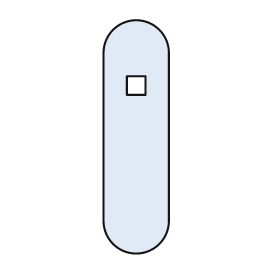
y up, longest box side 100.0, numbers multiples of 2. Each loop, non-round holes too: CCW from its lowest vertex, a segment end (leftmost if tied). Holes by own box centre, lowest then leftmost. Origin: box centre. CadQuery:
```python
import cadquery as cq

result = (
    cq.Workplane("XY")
    .moveTo(-14.0, -36.0)
    .threePointArc((0.0, -50.0), (14.0, -36.0))
    .lineTo(14.0, 36.0)
    .threePointArc((0.0, 50.0), (-14.0, 36.0))
    .close()
    .moveTo(-4.0, 18.0)
    .lineTo(4.0, 18.0)
    .lineTo(4.0, 26.0)
    .lineTo(-4.0, 26.0)
    .close()
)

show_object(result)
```